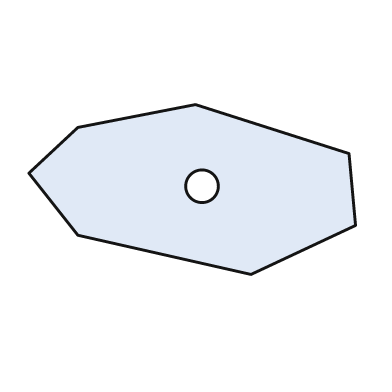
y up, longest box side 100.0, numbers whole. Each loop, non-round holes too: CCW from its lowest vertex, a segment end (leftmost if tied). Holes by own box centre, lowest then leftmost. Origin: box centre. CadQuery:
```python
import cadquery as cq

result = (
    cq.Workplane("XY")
    .moveTo(18.0, -26.0)
    .lineTo(50.0, -11.0)
    .lineTo(48.0, 11.0)
    .lineTo(1.0, 26.0)
    .lineTo(-35.0, 19.0)
    .lineTo(-50.0, 5.0)
    .lineTo(-35.0, -14.0)
    .close()
    .moveTo(3.0, 1.0)
    .circle(5.0)
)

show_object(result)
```